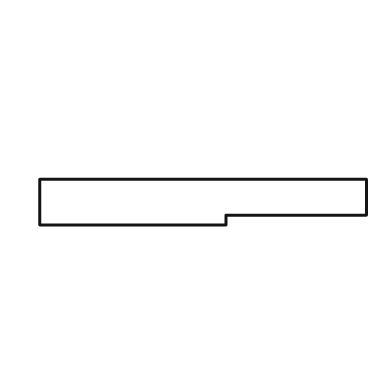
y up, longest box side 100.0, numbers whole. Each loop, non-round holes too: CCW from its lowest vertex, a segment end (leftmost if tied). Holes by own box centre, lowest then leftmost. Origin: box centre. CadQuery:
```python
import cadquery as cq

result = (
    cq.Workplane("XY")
    .moveTo(-50.0, -7.0)
    .lineTo(7.0, -7.0)
    .lineTo(7.0, -4.0)
    .lineTo(50.0, -4.0)
    .lineTo(50.0, 7.0)
    .lineTo(-50.0, 7.0)
    .close()
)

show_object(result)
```